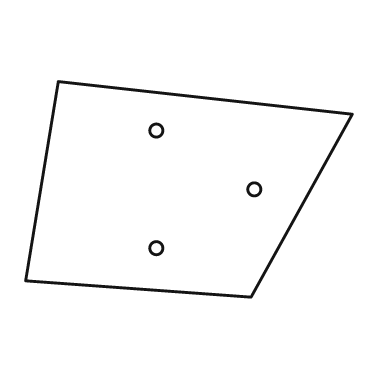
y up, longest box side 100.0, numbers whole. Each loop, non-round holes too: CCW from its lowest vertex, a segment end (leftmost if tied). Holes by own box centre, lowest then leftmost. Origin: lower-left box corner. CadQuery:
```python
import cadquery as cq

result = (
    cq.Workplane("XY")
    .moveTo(69.0, 0.0)
    .lineTo(100.0, 56.0)
    .lineTo(10.0, 66.0)
    .lineTo(0.0, 5.0)
    .close()
    .moveTo(40.0, 15.0)
    .circle(2.0)
    .moveTo(70.0, 33.0)
    .circle(2.0)
    .moveTo(40.0, 51.0)
    .circle(2.0)
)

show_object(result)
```